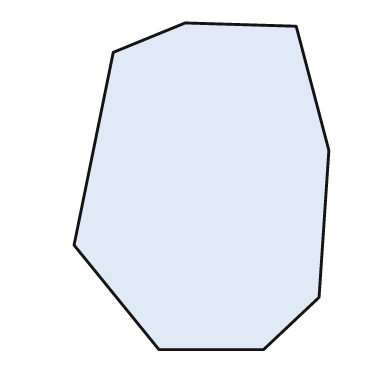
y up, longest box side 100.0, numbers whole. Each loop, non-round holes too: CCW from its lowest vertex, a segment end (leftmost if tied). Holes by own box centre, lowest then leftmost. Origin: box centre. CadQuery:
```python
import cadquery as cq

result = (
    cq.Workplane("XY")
    .moveTo(-13.0, -50.0)
    .lineTo(19.0, -50.0)
    .lineTo(36.0, -34.0)
    .lineTo(39.0, 11.0)
    .lineTo(29.0, 49.0)
    .lineTo(-5.0, 50.0)
    .lineTo(-27.0, 41.0)
    .lineTo(-39.0, -18.0)
    .close()
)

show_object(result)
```